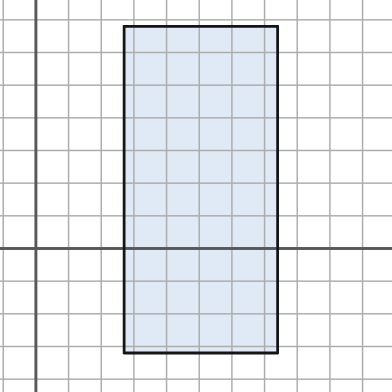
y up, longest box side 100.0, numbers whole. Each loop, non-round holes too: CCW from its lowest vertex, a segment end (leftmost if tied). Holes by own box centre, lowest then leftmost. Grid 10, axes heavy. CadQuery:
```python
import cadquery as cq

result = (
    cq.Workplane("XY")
    .moveTo(27.0, -32.0)
    .lineTo(74.0, -32.0)
    .lineTo(74.0, 68.0)
    .lineTo(27.0, 68.0)
    .close()
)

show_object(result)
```